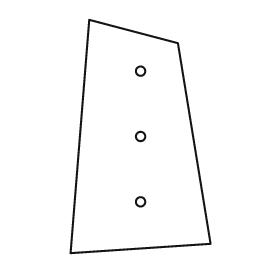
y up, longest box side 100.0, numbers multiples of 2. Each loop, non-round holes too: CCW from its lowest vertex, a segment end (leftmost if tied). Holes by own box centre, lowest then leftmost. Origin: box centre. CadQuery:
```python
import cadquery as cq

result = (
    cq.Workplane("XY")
    .moveTo(-30.0, -50.0)
    .lineTo(30.0, -46.0)
    .lineTo(16.0, 40.0)
    .lineTo(-22.0, 50.0)
    .close()
    .moveTo(0.0, -28.0)
    .circle(2.0)
    .moveTo(0.0, 0.0)
    .circle(2.0)
    .moveTo(0.0, 28.0)
    .circle(2.0)
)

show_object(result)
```